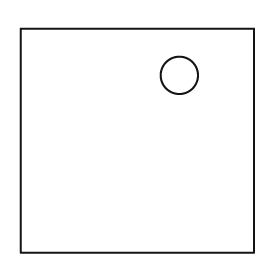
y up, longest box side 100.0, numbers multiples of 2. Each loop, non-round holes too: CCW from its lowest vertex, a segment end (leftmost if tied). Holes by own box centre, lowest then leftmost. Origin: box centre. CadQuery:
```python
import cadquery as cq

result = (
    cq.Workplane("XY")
    .moveTo(-50.0, -48.0)
    .lineTo(50.0, -48.0)
    .lineTo(50.0, 48.0)
    .lineTo(-50.0, 48.0)
    .close()
    .moveTo(18.0, 28.0)
    .circle(8.0)
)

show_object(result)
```